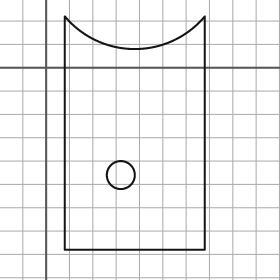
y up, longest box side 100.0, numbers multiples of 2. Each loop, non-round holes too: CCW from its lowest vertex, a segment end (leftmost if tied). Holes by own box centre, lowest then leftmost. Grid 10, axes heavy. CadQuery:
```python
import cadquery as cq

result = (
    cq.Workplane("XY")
    .moveTo(8.0, -78.0)
    .lineTo(68.0, -78.0)
    .lineTo(68.0, 22.0)
    .threePointArc((38.0, 8.0), (8.0, 22.0))
    .close()
    .moveTo(32.0, -46.0)
    .circle(6.0)
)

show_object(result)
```